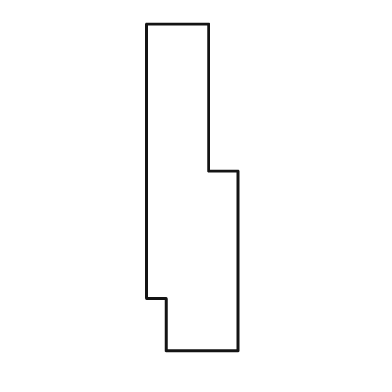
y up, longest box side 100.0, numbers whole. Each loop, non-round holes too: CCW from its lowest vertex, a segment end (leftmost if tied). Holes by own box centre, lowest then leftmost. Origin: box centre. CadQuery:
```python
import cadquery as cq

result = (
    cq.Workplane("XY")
    .moveTo(-8.0, -50.0)
    .lineTo(14.0, -50.0)
    .lineTo(14.0, 5.0)
    .lineTo(5.0, 5.0)
    .lineTo(5.0, 50.0)
    .lineTo(-14.0, 50.0)
    .lineTo(-14.0, -34.0)
    .lineTo(-8.0, -34.0)
    .close()
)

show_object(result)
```